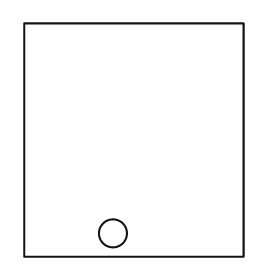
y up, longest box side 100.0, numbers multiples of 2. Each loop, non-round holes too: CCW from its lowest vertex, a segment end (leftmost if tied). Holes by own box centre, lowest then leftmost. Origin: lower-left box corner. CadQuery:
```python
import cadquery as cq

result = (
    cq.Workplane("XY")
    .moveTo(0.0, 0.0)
    .lineTo(94.0, 0.0)
    .lineTo(94.0, 100.0)
    .lineTo(0.0, 100.0)
    .close()
    .moveTo(38.0, 10.0)
    .circle(6.0)
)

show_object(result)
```